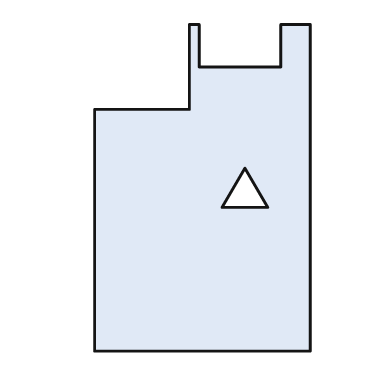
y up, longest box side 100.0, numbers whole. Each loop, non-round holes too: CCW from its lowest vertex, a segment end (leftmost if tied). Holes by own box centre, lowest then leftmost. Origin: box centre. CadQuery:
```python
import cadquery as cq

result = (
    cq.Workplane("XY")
    .moveTo(-33.0, -50.0)
    .lineTo(33.0, -50.0)
    .lineTo(33.0, 50.0)
    .lineTo(24.0, 50.0)
    .lineTo(24.0, 37.0)
    .lineTo(-1.0, 37.0)
    .lineTo(-1.0, 50.0)
    .lineTo(-4.0, 50.0)
    .lineTo(-4.0, 24.0)
    .lineTo(-33.0, 24.0)
    .close()
    .moveTo(6.0, -6.0)
    .lineTo(20.0, -6.0)
    .lineTo(13.0, 6.0)
    .close()
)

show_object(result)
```